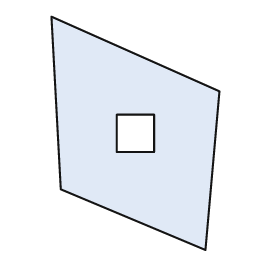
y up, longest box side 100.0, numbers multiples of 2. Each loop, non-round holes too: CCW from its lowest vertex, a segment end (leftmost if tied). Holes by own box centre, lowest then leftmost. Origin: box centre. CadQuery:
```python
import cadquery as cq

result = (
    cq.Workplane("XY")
    .moveTo(30.0, -50.0)
    .lineTo(36.0, 18.0)
    .lineTo(-36.0, 50.0)
    .lineTo(-32.0, -24.0)
    .close()
    .moveTo(-8.0, -8.0)
    .lineTo(8.0, -8.0)
    .lineTo(8.0, 8.0)
    .lineTo(-8.0, 8.0)
    .close()
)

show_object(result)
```